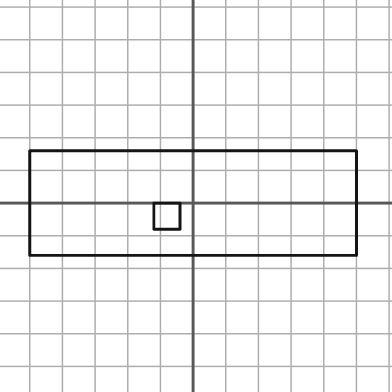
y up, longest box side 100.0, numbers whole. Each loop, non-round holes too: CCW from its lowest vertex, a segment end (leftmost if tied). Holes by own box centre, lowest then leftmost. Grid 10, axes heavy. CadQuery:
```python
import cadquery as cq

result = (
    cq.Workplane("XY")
    .moveTo(-50.0, -16.0)
    .lineTo(50.0, -16.0)
    .lineTo(50.0, 16.0)
    .lineTo(-50.0, 16.0)
    .close()
    .moveTo(-12.0, -8.0)
    .lineTo(-4.0, -8.0)
    .lineTo(-4.0, 0.0)
    .lineTo(-12.0, 0.0)
    .close()
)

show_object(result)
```